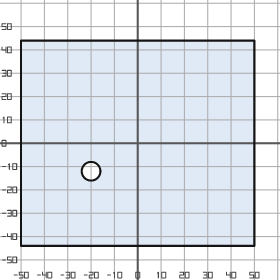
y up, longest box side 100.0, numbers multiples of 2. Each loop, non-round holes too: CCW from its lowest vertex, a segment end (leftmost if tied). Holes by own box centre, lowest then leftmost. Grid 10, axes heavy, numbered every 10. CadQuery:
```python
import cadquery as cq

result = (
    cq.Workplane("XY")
    .moveTo(-50.0, -44.0)
    .lineTo(50.0, -44.0)
    .lineTo(50.0, 44.0)
    .lineTo(-50.0, 44.0)
    .close()
    .moveTo(-20.0, -12.0)
    .circle(4.0)
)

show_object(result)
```